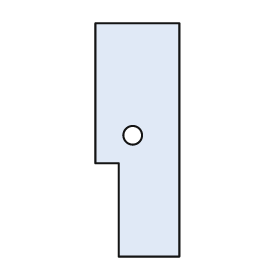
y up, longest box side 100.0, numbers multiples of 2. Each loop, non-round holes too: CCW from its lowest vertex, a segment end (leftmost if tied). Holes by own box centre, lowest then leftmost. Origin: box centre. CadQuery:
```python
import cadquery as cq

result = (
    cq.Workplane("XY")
    .moveTo(-8.0, -50.0)
    .lineTo(18.0, -50.0)
    .lineTo(18.0, 50.0)
    .lineTo(-18.0, 50.0)
    .lineTo(-18.0, -10.0)
    .lineTo(-8.0, -10.0)
    .close()
    .moveTo(-2.0, 2.0)
    .circle(4.0)
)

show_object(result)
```